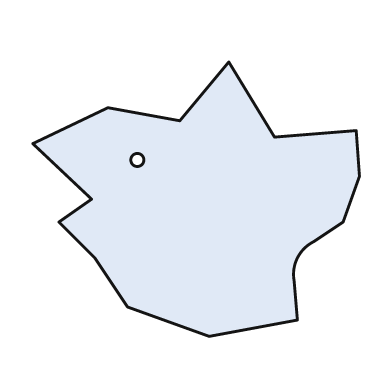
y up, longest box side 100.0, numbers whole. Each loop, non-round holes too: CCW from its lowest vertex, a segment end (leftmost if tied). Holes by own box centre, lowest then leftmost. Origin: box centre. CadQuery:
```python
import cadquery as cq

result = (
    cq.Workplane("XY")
    .moveTo(4.0, -42.0)
    .lineTo(31.0, -37.0)
    .lineTo(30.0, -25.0)
    .threePointArc((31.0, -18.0), (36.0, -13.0))
    .lineTo(45.0, -7.0)
    .lineTo(50.0, 7.0)
    .lineTo(49.0, 21.0)
    .lineTo(24.0, 19.0)
    .lineTo(10.0, 42.0)
    .lineTo(-5.0, 24.0)
    .lineTo(-27.0, 28.0)
    .lineTo(-50.0, 17.0)
    .lineTo(-32.0, 0.0)
    .lineTo(-42.0, -7.0)
    .lineTo(-31.0, -18.0)
    .lineTo(-21.0, -33.0)
    .close()
    .moveTo(-18.0, 12.0)
    .circle(2.0)
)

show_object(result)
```